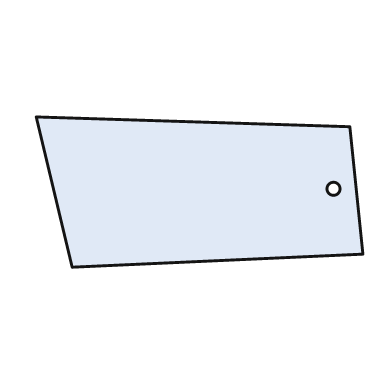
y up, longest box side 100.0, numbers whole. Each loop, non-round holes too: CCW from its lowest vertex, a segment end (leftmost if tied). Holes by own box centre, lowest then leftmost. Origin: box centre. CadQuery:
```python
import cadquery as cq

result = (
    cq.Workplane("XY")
    .moveTo(-39.0, -23.0)
    .lineTo(50.0, -19.0)
    .lineTo(46.0, 20.0)
    .lineTo(-50.0, 23.0)
    .close()
    .moveTo(41.0, 1.0)
    .circle(2.0)
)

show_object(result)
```